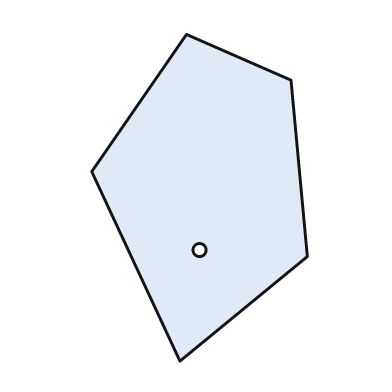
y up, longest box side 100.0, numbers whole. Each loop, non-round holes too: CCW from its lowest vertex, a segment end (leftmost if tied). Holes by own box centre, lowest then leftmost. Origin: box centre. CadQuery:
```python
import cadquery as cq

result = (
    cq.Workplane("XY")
    .moveTo(-6.0, -50.0)
    .lineTo(33.0, -18.0)
    .lineTo(28.0, 36.0)
    .lineTo(-4.0, 50.0)
    .lineTo(-33.0, 8.0)
    .close()
    .moveTo(0.0, -16.0)
    .circle(2.0)
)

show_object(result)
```